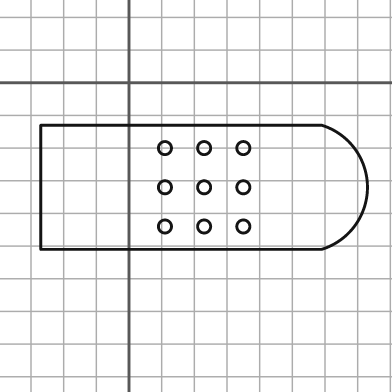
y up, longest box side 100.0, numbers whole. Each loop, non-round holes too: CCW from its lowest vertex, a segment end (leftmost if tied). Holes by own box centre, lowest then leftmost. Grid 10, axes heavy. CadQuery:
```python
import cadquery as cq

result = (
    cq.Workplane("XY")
    .moveTo(-27.0, -51.0)
    .lineTo(59.0, -51.0)
    .threePointArc((73.0, -32.0), (59.0, -13.0))
    .lineTo(-27.0, -13.0)
    .close()
    .moveTo(11.0, -44.0)
    .circle(2.0)
    .moveTo(23.0, -44.0)
    .circle(2.0)
    .moveTo(35.0, -44.0)
    .circle(2.0)
    .moveTo(11.0, -32.0)
    .circle(2.0)
    .moveTo(23.0, -32.0)
    .circle(2.0)
    .moveTo(35.0, -32.0)
    .circle(2.0)
    .moveTo(11.0, -20.0)
    .circle(2.0)
    .moveTo(23.0, -20.0)
    .circle(2.0)
    .moveTo(35.0, -20.0)
    .circle(2.0)
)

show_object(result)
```